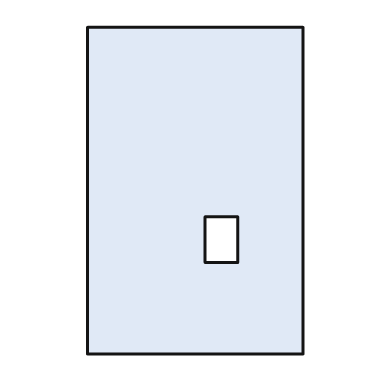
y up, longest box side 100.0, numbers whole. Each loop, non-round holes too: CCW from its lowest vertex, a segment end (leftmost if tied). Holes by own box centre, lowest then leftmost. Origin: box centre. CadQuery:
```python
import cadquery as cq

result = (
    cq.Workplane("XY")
    .moveTo(-33.0, -50.0)
    .lineTo(33.0, -50.0)
    .lineTo(33.0, 50.0)
    .lineTo(-33.0, 50.0)
    .close()
    .moveTo(3.0, -22.0)
    .lineTo(13.0, -22.0)
    .lineTo(13.0, -8.0)
    .lineTo(3.0, -8.0)
    .close()
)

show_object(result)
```